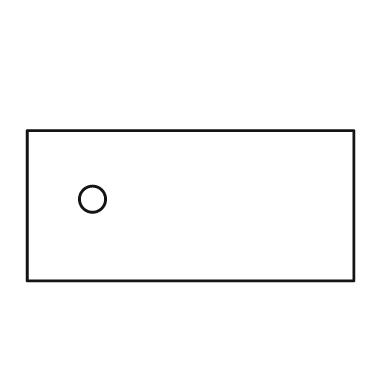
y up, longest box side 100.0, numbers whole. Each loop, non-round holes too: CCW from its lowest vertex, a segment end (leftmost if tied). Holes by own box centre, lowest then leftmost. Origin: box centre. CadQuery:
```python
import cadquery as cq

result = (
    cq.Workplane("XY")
    .moveTo(-50.0, -23.0)
    .lineTo(50.0, -23.0)
    .lineTo(50.0, 23.0)
    .lineTo(-50.0, 23.0)
    .close()
    .moveTo(-30.0, 2.0)
    .circle(4.0)
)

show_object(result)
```